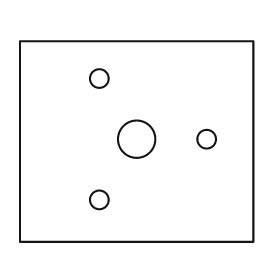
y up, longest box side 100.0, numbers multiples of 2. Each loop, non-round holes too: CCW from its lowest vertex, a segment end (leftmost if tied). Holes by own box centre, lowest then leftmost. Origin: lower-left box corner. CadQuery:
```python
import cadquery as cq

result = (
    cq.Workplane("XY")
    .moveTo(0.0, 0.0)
    .lineTo(100.0, 0.0)
    .lineTo(100.0, 86.0)
    .lineTo(0.0, 86.0)
    .close()
    .moveTo(34.0, 18.0)
    .circle(4.0)
    .moveTo(50.0, 44.0)
    .circle(8.0)
    .moveTo(80.0, 44.0)
    .circle(4.0)
    .moveTo(34.0, 70.0)
    .circle(4.0)
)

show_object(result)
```